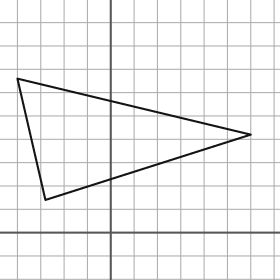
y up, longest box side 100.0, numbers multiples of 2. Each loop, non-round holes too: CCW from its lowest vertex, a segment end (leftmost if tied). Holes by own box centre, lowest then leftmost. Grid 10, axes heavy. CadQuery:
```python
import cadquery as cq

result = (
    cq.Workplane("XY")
    .moveTo(-28.0, 14.0)
    .lineTo(60.0, 42.0)
    .lineTo(-40.0, 66.0)
    .close()
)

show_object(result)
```